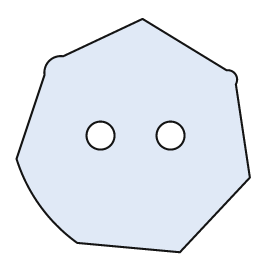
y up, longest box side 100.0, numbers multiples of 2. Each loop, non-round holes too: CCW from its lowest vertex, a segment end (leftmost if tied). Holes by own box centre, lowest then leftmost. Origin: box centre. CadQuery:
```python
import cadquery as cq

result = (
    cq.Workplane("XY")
    .moveTo(20.0, -50.0)
    .lineTo(50.0, -18.0)
    .lineTo(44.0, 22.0)
    .threePointArc((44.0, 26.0), (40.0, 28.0))
    .lineTo(4.0, 50.0)
    .lineTo(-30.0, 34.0)
    .threePointArc((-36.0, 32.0), (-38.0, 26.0))
    .lineTo(-50.0, -10.0)
    .threePointArc((-40.0, -30.0), (-24.0, -46.0))
    .close()
    .moveTo(-14.0, 0.0)
    .circle(6.0)
    .moveTo(16.0, 0.0)
    .circle(6.0)
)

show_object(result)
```